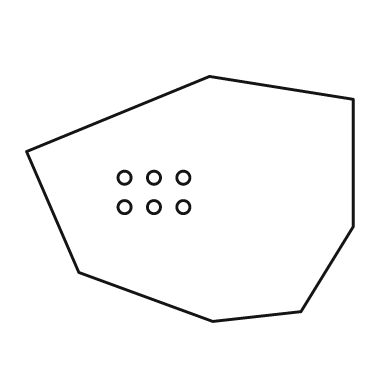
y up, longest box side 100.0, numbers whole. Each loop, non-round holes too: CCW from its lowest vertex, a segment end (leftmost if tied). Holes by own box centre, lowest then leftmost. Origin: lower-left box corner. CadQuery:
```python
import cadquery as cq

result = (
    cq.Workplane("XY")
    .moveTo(57.0, 0.0)
    .lineTo(84.0, 3.0)
    .lineTo(100.0, 29.0)
    .lineTo(100.0, 68.0)
    .lineTo(56.0, 75.0)
    .lineTo(0.0, 52.0)
    .lineTo(16.0, 15.0)
    .close()
    .moveTo(30.0, 35.0)
    .circle(2.0)
    .moveTo(39.0, 35.0)
    .circle(2.0)
    .moveTo(48.0, 35.0)
    .circle(2.0)
    .moveTo(30.0, 44.0)
    .circle(2.0)
    .moveTo(39.0, 44.0)
    .circle(2.0)
    .moveTo(48.0, 44.0)
    .circle(2.0)
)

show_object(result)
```